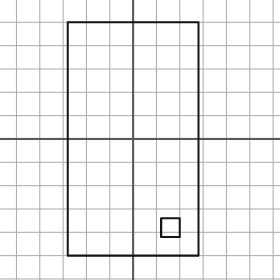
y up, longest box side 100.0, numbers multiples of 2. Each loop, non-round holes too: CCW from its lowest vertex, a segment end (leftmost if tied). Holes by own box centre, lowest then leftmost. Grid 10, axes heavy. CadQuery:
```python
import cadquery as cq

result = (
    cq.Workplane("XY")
    .moveTo(-28.0, -50.0)
    .lineTo(28.0, -50.0)
    .lineTo(28.0, 50.0)
    .lineTo(-28.0, 50.0)
    .close()
    .moveTo(12.0, -42.0)
    .lineTo(20.0, -42.0)
    .lineTo(20.0, -34.0)
    .lineTo(12.0, -34.0)
    .close()
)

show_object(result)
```